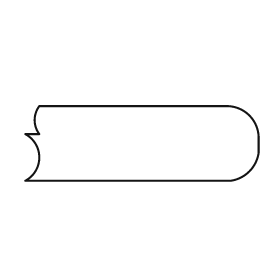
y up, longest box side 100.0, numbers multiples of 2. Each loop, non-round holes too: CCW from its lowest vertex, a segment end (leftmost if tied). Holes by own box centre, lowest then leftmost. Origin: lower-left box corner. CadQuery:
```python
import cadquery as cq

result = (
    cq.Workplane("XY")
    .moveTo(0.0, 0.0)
    .lineTo(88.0, 0.0)
    .threePointArc((96.0, 4.0), (100.0, 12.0))
    .lineTo(100.0, 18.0)
    .threePointArc((96.0, 28.0), (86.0, 32.0))
    .lineTo(6.0, 32.0)
    .threePointArc((4.0, 26.0), (6.0, 20.0))
    .lineTo(0.0, 20.0)
    .threePointArc((6.0, 10.0), (0.0, 0.0))
    .close()
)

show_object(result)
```